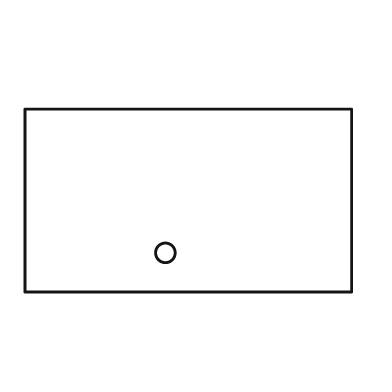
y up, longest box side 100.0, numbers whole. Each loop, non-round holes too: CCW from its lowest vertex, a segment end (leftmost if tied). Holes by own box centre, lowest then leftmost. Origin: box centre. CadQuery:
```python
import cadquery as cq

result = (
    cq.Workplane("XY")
    .moveTo(-50.0, -28.0)
    .lineTo(50.0, -28.0)
    .lineTo(50.0, 28.0)
    .lineTo(-50.0, 28.0)
    .close()
    .moveTo(-7.0, -16.0)
    .circle(3.0)
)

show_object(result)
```